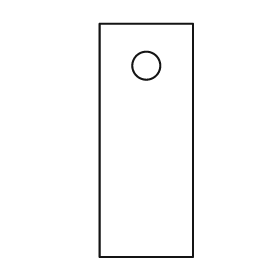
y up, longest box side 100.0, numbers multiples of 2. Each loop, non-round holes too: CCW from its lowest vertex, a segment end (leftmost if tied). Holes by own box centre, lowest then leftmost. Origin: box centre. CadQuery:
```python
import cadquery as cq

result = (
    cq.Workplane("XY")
    .moveTo(-20.0, -50.0)
    .lineTo(20.0, -50.0)
    .lineTo(20.0, 50.0)
    .lineTo(-20.0, 50.0)
    .close()
    .moveTo(0.0, 32.0)
    .circle(6.0)
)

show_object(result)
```